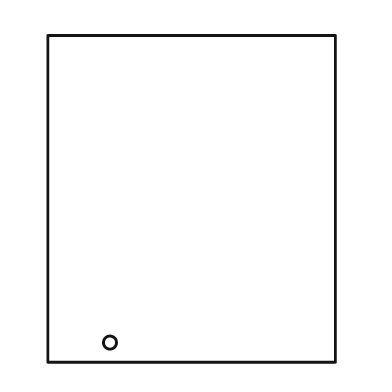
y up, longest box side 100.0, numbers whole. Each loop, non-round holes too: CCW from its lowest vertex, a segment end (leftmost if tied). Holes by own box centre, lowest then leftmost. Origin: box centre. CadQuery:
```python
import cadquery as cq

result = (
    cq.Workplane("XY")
    .moveTo(-44.0, -50.0)
    .lineTo(44.0, -50.0)
    .lineTo(44.0, 50.0)
    .lineTo(-44.0, 50.0)
    .close()
    .moveTo(-25.0, -44.0)
    .circle(2.0)
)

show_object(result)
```